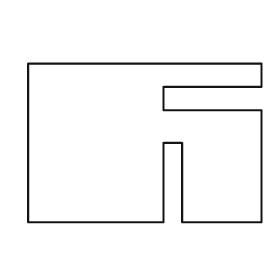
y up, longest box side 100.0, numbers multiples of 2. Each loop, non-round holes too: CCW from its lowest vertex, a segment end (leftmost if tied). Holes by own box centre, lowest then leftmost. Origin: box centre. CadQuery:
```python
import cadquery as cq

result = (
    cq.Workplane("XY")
    .moveTo(-50.0, -34.0)
    .lineTo(8.0, -34.0)
    .lineTo(8.0, 0.0)
    .lineTo(16.0, 0.0)
    .lineTo(16.0, -34.0)
    .lineTo(50.0, -34.0)
    .lineTo(50.0, 14.0)
    .lineTo(8.0, 14.0)
    .lineTo(8.0, 24.0)
    .lineTo(50.0, 24.0)
    .lineTo(50.0, 34.0)
    .lineTo(-50.0, 34.0)
    .close()
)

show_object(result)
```